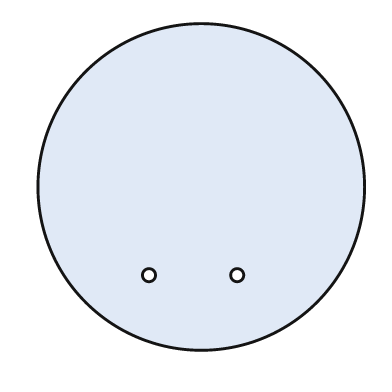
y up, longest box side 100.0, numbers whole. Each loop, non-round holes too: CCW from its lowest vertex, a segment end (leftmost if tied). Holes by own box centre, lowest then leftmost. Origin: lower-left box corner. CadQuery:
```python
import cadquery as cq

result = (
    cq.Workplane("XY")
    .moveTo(50.0, 50.0)
    .circle(50.0)
    .moveTo(34.0, 23.0)
    .circle(2.0)
    .moveTo(61.0, 23.0)
    .circle(2.0)
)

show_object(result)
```